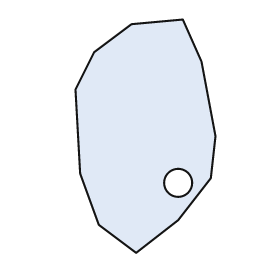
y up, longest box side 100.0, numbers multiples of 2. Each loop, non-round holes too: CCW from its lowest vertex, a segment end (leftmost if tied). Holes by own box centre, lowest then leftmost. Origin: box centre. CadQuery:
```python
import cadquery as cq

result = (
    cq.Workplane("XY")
    .moveTo(-4.0, -50.0)
    .lineTo(14.0, -36.0)
    .lineTo(28.0, -18.0)
    .lineTo(30.0, 0.0)
    .lineTo(24.0, 32.0)
    .lineTo(16.0, 50.0)
    .lineTo(-6.0, 48.0)
    .lineTo(-22.0, 36.0)
    .lineTo(-30.0, 20.0)
    .lineTo(-28.0, -16.0)
    .lineTo(-20.0, -38.0)
    .close()
    .moveTo(14.0, -20.0)
    .circle(6.0)
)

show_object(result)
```